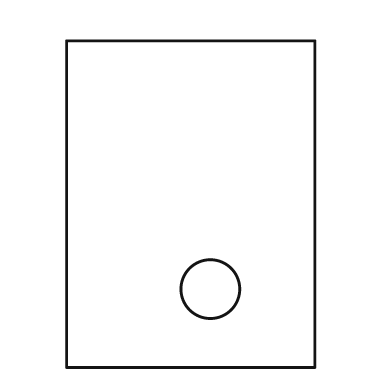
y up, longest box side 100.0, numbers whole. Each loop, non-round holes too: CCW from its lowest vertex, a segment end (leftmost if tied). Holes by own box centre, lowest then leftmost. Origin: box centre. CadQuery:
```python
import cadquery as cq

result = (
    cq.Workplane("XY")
    .moveTo(-38.0, -50.0)
    .lineTo(38.0, -50.0)
    .lineTo(38.0, 50.0)
    .lineTo(-38.0, 50.0)
    .close()
    .moveTo(6.0, -26.0)
    .circle(9.0)
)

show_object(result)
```